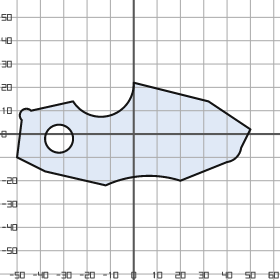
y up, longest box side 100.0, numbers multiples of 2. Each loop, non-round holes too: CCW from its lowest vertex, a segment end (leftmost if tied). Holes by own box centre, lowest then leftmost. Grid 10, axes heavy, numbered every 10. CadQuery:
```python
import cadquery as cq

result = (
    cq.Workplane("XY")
    .moveTo(-12.0, -22.0)
    .threePointArc((4.0, -18.0), (20.0, -20.0))
    .lineTo(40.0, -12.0)
    .threePointArc((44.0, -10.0), (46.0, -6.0))
    .lineTo(50.0, 2.0)
    .lineTo(32.0, 14.0)
    .lineTo(0.0, 22.0)
    .threePointArc((-10.0, 8.0), (-26.0, 14.0))
    .lineTo(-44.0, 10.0)
    .threePointArc((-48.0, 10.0), (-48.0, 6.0))
    .lineTo(-50.0, -10.0)
    .lineTo(-38.0, -16.0)
    .close()
    .moveTo(-32.0, -2.0)
    .circle(6.0)
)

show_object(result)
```